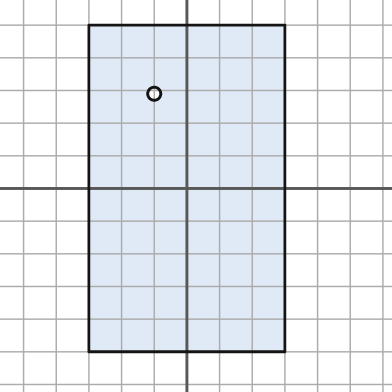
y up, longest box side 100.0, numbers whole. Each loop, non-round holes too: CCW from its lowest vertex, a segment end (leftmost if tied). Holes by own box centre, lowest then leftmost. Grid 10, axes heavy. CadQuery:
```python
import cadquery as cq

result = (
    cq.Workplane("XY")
    .moveTo(-30.0, -50.0)
    .lineTo(30.0, -50.0)
    .lineTo(30.0, 50.0)
    .lineTo(-30.0, 50.0)
    .close()
    .moveTo(-10.0, 29.0)
    .circle(2.0)
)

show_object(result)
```